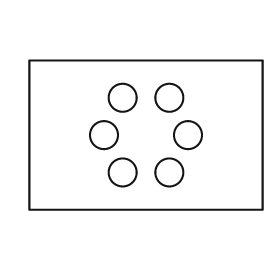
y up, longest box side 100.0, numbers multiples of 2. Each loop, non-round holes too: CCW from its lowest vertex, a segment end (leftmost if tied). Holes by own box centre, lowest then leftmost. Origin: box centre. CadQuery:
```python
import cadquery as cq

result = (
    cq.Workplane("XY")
    .moveTo(-50.0, -32.0)
    .lineTo(50.0, -32.0)
    .lineTo(50.0, 32.0)
    .lineTo(-50.0, 32.0)
    .close()
    .moveTo(-10.0, -16.0)
    .circle(6.0)
    .moveTo(10.0, -16.0)
    .circle(6.0)
    .moveTo(-18.0, 0.0)
    .circle(6.0)
    .moveTo(18.0, 0.0)
    .circle(6.0)
    .moveTo(-10.0, 16.0)
    .circle(6.0)
    .moveTo(10.0, 16.0)
    .circle(6.0)
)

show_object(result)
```